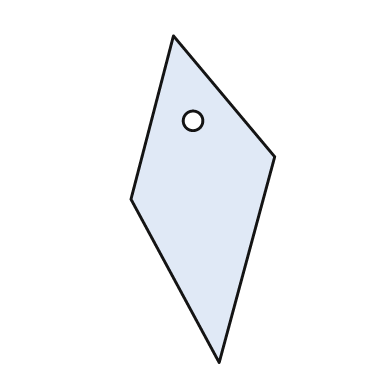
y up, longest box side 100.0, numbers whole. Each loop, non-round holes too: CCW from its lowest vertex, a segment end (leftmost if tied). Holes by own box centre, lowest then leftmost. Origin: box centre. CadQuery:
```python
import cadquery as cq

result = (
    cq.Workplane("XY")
    .moveTo(5.0, -50.0)
    .lineTo(22.0, 13.0)
    .lineTo(-9.0, 50.0)
    .lineTo(-22.0, 0.0)
    .close()
    .moveTo(-3.0, 24.0)
    .circle(3.0)
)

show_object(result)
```